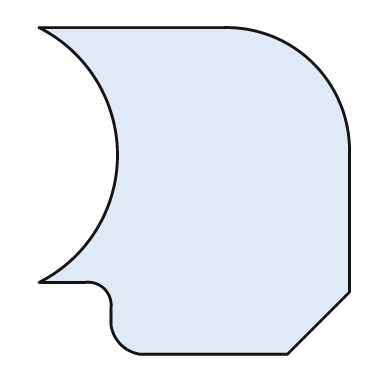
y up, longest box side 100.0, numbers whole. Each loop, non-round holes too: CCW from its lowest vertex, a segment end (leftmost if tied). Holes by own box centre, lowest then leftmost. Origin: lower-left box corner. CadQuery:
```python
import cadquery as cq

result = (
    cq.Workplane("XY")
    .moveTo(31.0, 0.0)
    .lineTo(76.0, 0.0)
    .lineTo(95.0, 19.0)
    .lineTo(95.0, 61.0)
    .threePointArc((84.0, 89.0), (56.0, 100.0))
    .lineTo(0.0, 100.0)
    .threePointArc((24.0, 61.0), (0.0, 22.0))
    .lineTo(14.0, 22.0)
    .threePointArc((20.0, 20.0), (22.0, 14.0))
    .lineTo(22.0, 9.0)
    .threePointArc((25.0, 3.0), (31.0, 0.0))
    .close()
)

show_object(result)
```